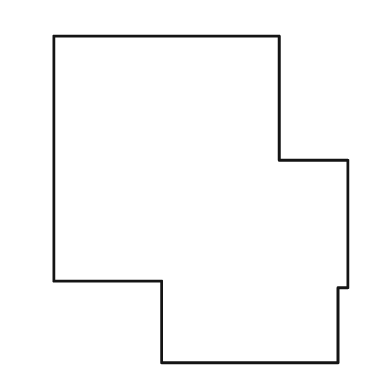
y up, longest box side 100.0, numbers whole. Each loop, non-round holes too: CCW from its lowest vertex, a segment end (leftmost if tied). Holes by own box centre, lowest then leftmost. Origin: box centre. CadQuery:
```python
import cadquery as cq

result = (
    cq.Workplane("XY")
    .moveTo(-12.0, -50.0)
    .lineTo(42.0, -50.0)
    .lineTo(42.0, -27.0)
    .lineTo(45.0, -27.0)
    .lineTo(45.0, 12.0)
    .lineTo(24.0, 12.0)
    .lineTo(24.0, 50.0)
    .lineTo(-45.0, 50.0)
    .lineTo(-45.0, -25.0)
    .lineTo(-12.0, -25.0)
    .close()
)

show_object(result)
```